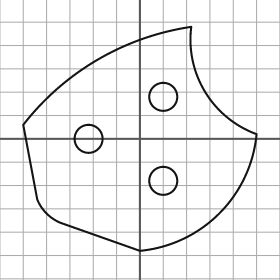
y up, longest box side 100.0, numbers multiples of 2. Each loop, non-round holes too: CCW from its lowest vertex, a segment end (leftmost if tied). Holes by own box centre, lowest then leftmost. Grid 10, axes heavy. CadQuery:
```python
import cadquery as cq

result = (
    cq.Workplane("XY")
    .moveTo(0.0, -48.0)
    .threePointArc((34.0, -32.0), (50.0, 2.0))
    .threePointArc((28.0, 20.0), (22.0, 48.0))
    .threePointArc((-18.0, 34.0), (-50.0, 6.0))
    .lineTo(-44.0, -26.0)
    .threePointArc((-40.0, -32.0), (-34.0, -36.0))
    .close()
    .moveTo(10.0, -18.0)
    .circle(6.0)
    .moveTo(-22.0, 0.0)
    .circle(6.0)
    .moveTo(10.0, 18.0)
    .circle(6.0)
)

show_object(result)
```